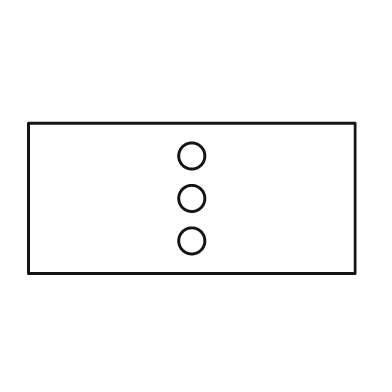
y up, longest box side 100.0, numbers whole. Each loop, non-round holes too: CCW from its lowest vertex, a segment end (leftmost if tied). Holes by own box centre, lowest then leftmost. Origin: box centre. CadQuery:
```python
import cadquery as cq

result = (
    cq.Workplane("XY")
    .moveTo(-50.0, -23.0)
    .lineTo(50.0, -23.0)
    .lineTo(50.0, 23.0)
    .lineTo(-50.0, 23.0)
    .close()
    .moveTo(0.0, -13.0)
    .circle(4.0)
    .moveTo(0.0, 0.0)
    .circle(4.0)
    .moveTo(0.0, 13.0)
    .circle(4.0)
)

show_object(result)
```